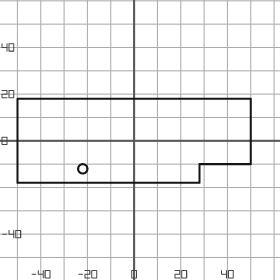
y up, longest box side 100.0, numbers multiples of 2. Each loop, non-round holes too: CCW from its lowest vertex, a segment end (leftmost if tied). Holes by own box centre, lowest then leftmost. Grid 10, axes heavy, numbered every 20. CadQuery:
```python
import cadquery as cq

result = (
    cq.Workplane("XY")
    .moveTo(-50.0, -18.0)
    .lineTo(28.0, -18.0)
    .lineTo(28.0, -10.0)
    .lineTo(50.0, -10.0)
    .lineTo(50.0, 18.0)
    .lineTo(-50.0, 18.0)
    .close()
    .moveTo(-22.0, -12.0)
    .circle(2.0)
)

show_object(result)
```